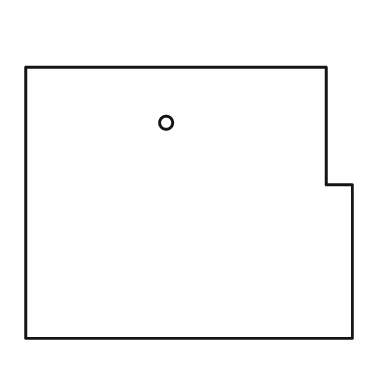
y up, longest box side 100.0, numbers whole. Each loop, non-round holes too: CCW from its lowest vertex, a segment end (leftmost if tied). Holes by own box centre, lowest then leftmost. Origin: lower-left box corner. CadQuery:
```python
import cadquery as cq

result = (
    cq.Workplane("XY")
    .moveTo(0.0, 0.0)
    .lineTo(100.0, 0.0)
    .lineTo(100.0, 47.0)
    .lineTo(92.0, 47.0)
    .lineTo(92.0, 83.0)
    .lineTo(0.0, 83.0)
    .close()
    .moveTo(43.0, 66.0)
    .circle(2.0)
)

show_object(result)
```